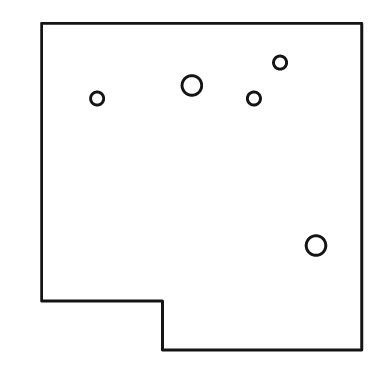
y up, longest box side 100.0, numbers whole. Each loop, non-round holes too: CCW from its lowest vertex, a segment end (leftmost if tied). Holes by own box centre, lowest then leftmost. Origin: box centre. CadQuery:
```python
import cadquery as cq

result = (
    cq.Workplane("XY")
    .moveTo(-12.0, -50.0)
    .lineTo(49.0, -50.0)
    .lineTo(49.0, 50.0)
    .lineTo(-49.0, 50.0)
    .lineTo(-49.0, -35.0)
    .lineTo(-12.0, -35.0)
    .close()
    .moveTo(35.0, -18.0)
    .circle(3.0)
    .moveTo(-32.0, 27.0)
    .circle(2.0)
    .moveTo(16.0, 27.0)
    .circle(2.0)
    .moveTo(-3.0, 31.0)
    .circle(3.0)
    .moveTo(24.0, 38.0)
    .circle(2.0)
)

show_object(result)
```